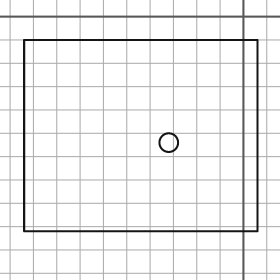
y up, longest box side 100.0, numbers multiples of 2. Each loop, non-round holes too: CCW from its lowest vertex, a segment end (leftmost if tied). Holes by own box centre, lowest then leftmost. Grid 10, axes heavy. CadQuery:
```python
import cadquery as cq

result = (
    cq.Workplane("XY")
    .moveTo(-94.0, -92.0)
    .lineTo(6.0, -92.0)
    .lineTo(6.0, -10.0)
    .lineTo(-94.0, -10.0)
    .close()
    .moveTo(-32.0, -54.0)
    .circle(4.0)
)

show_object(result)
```